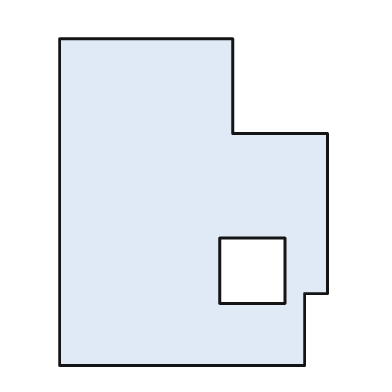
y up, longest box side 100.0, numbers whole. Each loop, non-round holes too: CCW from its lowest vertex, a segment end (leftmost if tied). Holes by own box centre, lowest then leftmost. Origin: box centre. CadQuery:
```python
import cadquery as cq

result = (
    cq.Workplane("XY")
    .moveTo(-41.0, -50.0)
    .lineTo(34.0, -50.0)
    .lineTo(34.0, -28.0)
    .lineTo(41.0, -28.0)
    .lineTo(41.0, 21.0)
    .lineTo(12.0, 21.0)
    .lineTo(12.0, 50.0)
    .lineTo(-41.0, 50.0)
    .close()
    .moveTo(8.0, -31.0)
    .lineTo(28.0, -31.0)
    .lineTo(28.0, -11.0)
    .lineTo(8.0, -11.0)
    .close()
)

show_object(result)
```